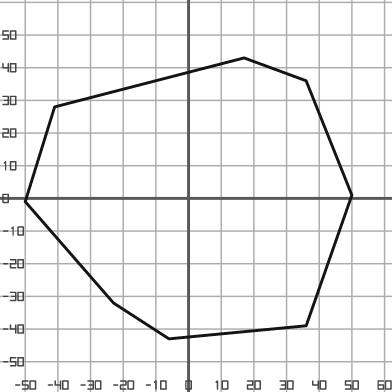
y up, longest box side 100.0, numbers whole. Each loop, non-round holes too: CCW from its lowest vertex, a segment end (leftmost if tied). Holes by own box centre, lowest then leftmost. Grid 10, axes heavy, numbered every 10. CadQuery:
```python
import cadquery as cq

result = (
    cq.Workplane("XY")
    .moveTo(-6.0, -43.0)
    .lineTo(36.0, -39.0)
    .lineTo(50.0, 1.0)
    .lineTo(36.0, 36.0)
    .lineTo(17.0, 43.0)
    .lineTo(-41.0, 28.0)
    .lineTo(-50.0, -1.0)
    .lineTo(-23.0, -32.0)
    .close()
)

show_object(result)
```